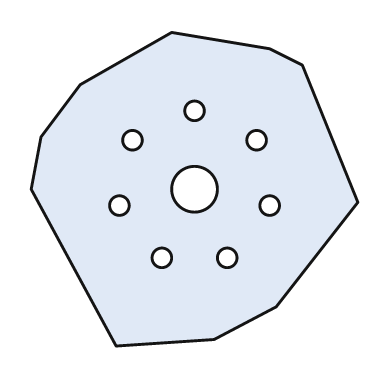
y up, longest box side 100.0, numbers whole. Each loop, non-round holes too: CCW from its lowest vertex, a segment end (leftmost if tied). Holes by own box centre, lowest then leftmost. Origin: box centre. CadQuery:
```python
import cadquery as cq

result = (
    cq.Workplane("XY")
    .moveTo(-24.0, -48.0)
    .lineTo(6.0, -46.0)
    .lineTo(25.0, -36.0)
    .lineTo(50.0, -4.0)
    .lineTo(33.0, 38.0)
    .lineTo(23.0, 43.0)
    .lineTo(-7.0, 48.0)
    .lineTo(-35.0, 32.0)
    .lineTo(-47.0, 16.0)
    .lineTo(-50.0, 0.0)
    .close()
    .moveTo(-10.0, -21.0)
    .circle(3.0)
    .moveTo(10.0, -21.0)
    .circle(3.0)
    .moveTo(-23.0, -5.0)
    .circle(3.0)
    .moveTo(23.0, -5.0)
    .circle(3.0)
    .moveTo(0.0, 0.0)
    .circle(7.0)
    .moveTo(-19.0, 15.0)
    .circle(3.0)
    .moveTo(19.0, 15.0)
    .circle(3.0)
    .moveTo(0.0, 24.0)
    .circle(3.0)
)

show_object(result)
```